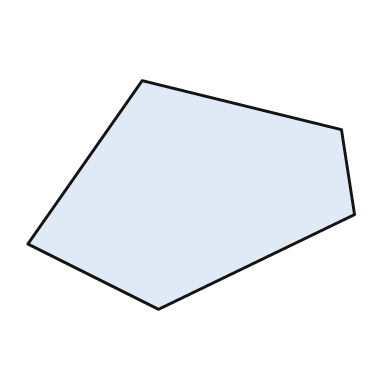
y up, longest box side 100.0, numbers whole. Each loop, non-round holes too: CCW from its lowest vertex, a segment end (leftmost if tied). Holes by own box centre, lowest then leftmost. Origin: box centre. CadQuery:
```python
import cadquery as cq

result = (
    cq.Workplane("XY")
    .moveTo(-10.0, -35.0)
    .lineTo(50.0, -6.0)
    .lineTo(46.0, 20.0)
    .lineTo(-15.0, 35.0)
    .lineTo(-50.0, -15.0)
    .close()
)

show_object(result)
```